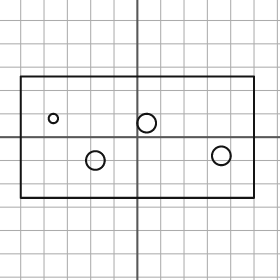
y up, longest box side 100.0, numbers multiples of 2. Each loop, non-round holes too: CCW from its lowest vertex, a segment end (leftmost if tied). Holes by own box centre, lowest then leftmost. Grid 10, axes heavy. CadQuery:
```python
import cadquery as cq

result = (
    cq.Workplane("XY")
    .moveTo(-50.0, -26.0)
    .lineTo(50.0, -26.0)
    .lineTo(50.0, 26.0)
    .lineTo(-50.0, 26.0)
    .close()
    .moveTo(-18.0, -10.0)
    .circle(4.0)
    .moveTo(36.0, -8.0)
    .circle(4.0)
    .moveTo(4.0, 6.0)
    .circle(4.0)
    .moveTo(-36.0, 8.0)
    .circle(2.0)
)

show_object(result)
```